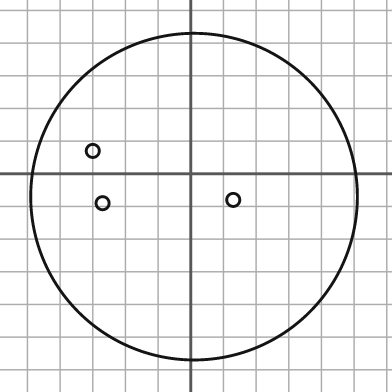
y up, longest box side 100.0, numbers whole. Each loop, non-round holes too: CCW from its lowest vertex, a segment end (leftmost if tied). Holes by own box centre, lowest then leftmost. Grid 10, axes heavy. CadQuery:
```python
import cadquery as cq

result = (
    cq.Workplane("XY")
    .moveTo(1.0, -7.0)
    .circle(50.0)
    .moveTo(-27.0, -9.0)
    .circle(2.0)
    .moveTo(13.0, -8.0)
    .circle(2.0)
    .moveTo(-30.0, 7.0)
    .circle(2.0)
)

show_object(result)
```